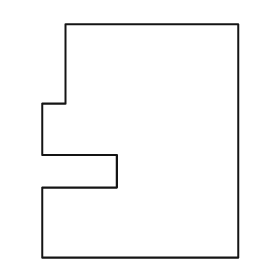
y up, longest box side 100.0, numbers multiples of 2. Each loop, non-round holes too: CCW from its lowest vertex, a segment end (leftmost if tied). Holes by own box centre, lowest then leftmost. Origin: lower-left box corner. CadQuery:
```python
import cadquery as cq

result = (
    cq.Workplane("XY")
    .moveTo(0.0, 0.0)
    .lineTo(84.0, 0.0)
    .lineTo(84.0, 100.0)
    .lineTo(10.0, 100.0)
    .lineTo(10.0, 66.0)
    .lineTo(0.0, 66.0)
    .lineTo(0.0, 44.0)
    .lineTo(32.0, 44.0)
    .lineTo(32.0, 30.0)
    .lineTo(0.0, 30.0)
    .close()
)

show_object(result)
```